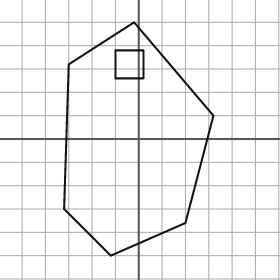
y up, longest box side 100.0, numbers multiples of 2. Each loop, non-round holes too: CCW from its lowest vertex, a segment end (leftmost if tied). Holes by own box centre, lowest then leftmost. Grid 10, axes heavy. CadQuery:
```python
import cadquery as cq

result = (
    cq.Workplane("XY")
    .moveTo(-12.0, -50.0)
    .lineTo(20.0, -36.0)
    .lineTo(32.0, 10.0)
    .lineTo(-2.0, 50.0)
    .lineTo(-30.0, 32.0)
    .lineTo(-32.0, -30.0)
    .close()
    .moveTo(-10.0, 26.0)
    .lineTo(2.0, 26.0)
    .lineTo(2.0, 38.0)
    .lineTo(-10.0, 38.0)
    .close()
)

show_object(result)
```